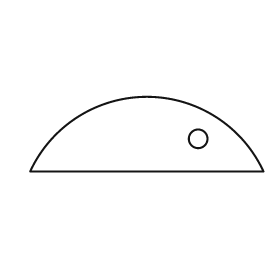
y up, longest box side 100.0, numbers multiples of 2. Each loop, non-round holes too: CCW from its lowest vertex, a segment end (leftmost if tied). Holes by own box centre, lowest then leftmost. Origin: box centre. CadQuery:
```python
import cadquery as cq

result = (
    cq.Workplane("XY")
    .moveTo(-50.0, -16.0)
    .lineTo(50.0, -16.0)
    .threePointArc((0.0, 16.0), (-50.0, -16.0))
    .close()
    .moveTo(22.0, -2.0)
    .circle(4.0)
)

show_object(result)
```